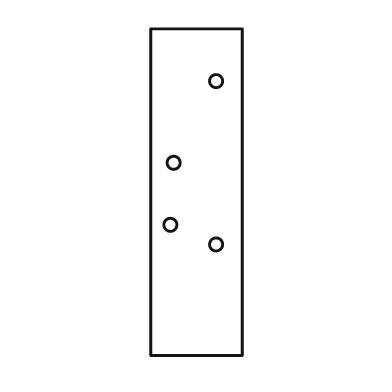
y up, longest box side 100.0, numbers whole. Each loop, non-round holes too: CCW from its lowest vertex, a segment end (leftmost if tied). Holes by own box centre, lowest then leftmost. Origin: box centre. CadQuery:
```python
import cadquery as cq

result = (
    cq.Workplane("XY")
    .moveTo(-14.0, -50.0)
    .lineTo(14.0, -50.0)
    .lineTo(14.0, 50.0)
    .lineTo(-14.0, 50.0)
    .close()
    .moveTo(6.0, -16.0)
    .circle(2.0)
    .moveTo(-8.0, -10.0)
    .circle(2.0)
    .moveTo(-7.0, 9.0)
    .circle(2.0)
    .moveTo(6.0, 34.0)
    .circle(2.0)
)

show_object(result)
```